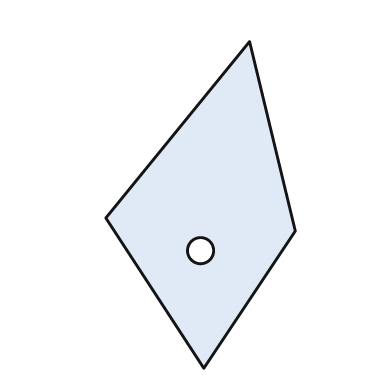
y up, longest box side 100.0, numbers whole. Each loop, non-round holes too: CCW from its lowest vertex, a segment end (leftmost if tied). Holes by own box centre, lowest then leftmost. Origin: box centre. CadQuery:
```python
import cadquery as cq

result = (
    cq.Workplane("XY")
    .moveTo(1.0, -50.0)
    .lineTo(29.0, -8.0)
    .lineTo(15.0, 50.0)
    .lineTo(-29.0, -4.0)
    .close()
    .moveTo(0.0, -14.0)
    .circle(4.0)
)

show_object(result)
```